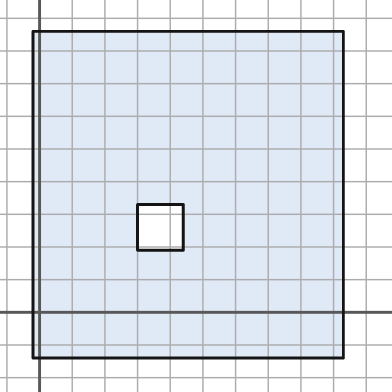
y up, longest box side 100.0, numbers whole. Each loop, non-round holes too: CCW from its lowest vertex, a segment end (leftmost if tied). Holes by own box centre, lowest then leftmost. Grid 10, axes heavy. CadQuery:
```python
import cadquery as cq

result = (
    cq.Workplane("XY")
    .moveTo(-2.0, -14.0)
    .lineTo(93.0, -14.0)
    .lineTo(93.0, 86.0)
    .lineTo(-2.0, 86.0)
    .close()
    .moveTo(30.0, 19.0)
    .lineTo(44.0, 19.0)
    .lineTo(44.0, 33.0)
    .lineTo(30.0, 33.0)
    .close()
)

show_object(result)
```